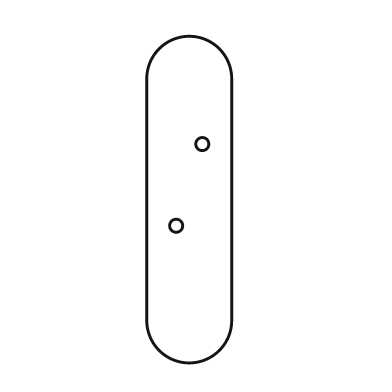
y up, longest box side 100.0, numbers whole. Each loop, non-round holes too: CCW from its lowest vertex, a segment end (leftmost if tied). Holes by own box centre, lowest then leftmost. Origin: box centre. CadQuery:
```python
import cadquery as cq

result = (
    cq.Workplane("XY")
    .moveTo(-13.0, -37.0)
    .threePointArc((0.0, -50.0), (13.0, -37.0))
    .lineTo(13.0, 37.0)
    .threePointArc((0.0, 50.0), (-13.0, 37.0))
    .close()
    .moveTo(-4.0, -8.0)
    .circle(2.0)
    .moveTo(4.0, 17.0)
    .circle(2.0)
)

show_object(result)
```